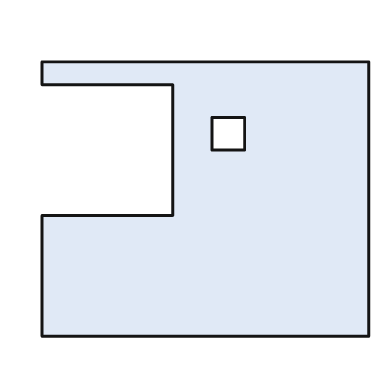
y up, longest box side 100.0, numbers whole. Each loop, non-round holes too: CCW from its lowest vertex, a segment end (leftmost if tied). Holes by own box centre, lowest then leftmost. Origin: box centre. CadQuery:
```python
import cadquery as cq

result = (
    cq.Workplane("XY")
    .moveTo(-50.0, -42.0)
    .lineTo(50.0, -42.0)
    .lineTo(50.0, 42.0)
    .lineTo(-50.0, 42.0)
    .lineTo(-50.0, 35.0)
    .lineTo(-10.0, 35.0)
    .lineTo(-10.0, -5.0)
    .lineTo(-50.0, -5.0)
    .close()
    .moveTo(2.0, 15.0)
    .lineTo(12.0, 15.0)
    .lineTo(12.0, 25.0)
    .lineTo(2.0, 25.0)
    .close()
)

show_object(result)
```